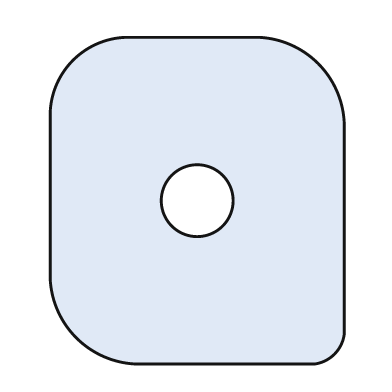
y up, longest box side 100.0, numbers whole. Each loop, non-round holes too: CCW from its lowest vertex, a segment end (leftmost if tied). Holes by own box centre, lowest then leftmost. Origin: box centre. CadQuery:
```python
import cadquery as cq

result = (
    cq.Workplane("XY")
    .moveTo(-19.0, -50.0)
    .lineTo(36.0, -50.0)
    .threePointArc((42.0, -47.0), (45.0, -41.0))
    .lineTo(45.0, 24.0)
    .threePointArc((37.0, 42.0), (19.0, 50.0))
    .lineTo(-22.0, 50.0)
    .threePointArc((-38.0, 43.0), (-45.0, 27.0))
    .lineTo(-45.0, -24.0)
    .threePointArc((-37.0, -42.0), (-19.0, -50.0))
    .close()
    .moveTo(0.0, 0.0)
    .circle(11.0)
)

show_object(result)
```